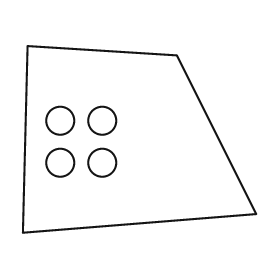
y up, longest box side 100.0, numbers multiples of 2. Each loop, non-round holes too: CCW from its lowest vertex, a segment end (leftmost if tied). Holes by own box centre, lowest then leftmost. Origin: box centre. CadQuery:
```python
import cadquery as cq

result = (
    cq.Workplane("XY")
    .moveTo(-50.0, -40.0)
    .lineTo(50.0, -32.0)
    .lineTo(16.0, 36.0)
    .lineTo(-48.0, 40.0)
    .close()
    .moveTo(-34.0, -10.0)
    .circle(6.0)
    .moveTo(-16.0, -10.0)
    .circle(6.0)
    .moveTo(-34.0, 8.0)
    .circle(6.0)
    .moveTo(-16.0, 8.0)
    .circle(6.0)
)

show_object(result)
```